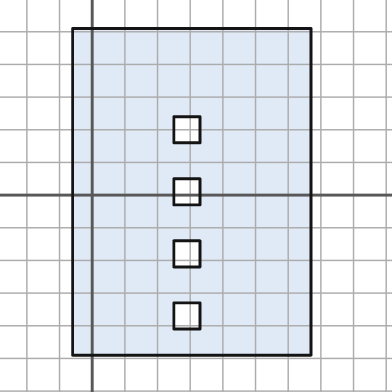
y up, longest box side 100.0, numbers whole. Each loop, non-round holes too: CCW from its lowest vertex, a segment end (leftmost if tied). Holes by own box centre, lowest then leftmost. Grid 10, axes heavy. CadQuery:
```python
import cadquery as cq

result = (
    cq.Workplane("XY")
    .moveTo(-6.0, -49.0)
    .lineTo(67.0, -49.0)
    .lineTo(67.0, 51.0)
    .lineTo(-6.0, 51.0)
    .close()
    .moveTo(25.0, -41.0)
    .lineTo(33.0, -41.0)
    .lineTo(33.0, -33.0)
    .lineTo(25.0, -33.0)
    .close()
    .moveTo(25.0, -22.0)
    .lineTo(33.0, -22.0)
    .lineTo(33.0, -14.0)
    .lineTo(25.0, -14.0)
    .close()
    .moveTo(25.0, -3.0)
    .lineTo(33.0, -3.0)
    .lineTo(33.0, 5.0)
    .lineTo(25.0, 5.0)
    .close()
    .moveTo(25.0, 16.0)
    .lineTo(33.0, 16.0)
    .lineTo(33.0, 24.0)
    .lineTo(25.0, 24.0)
    .close()
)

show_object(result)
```